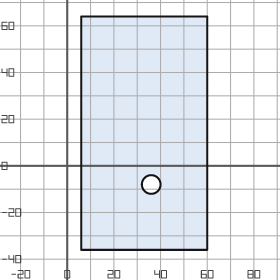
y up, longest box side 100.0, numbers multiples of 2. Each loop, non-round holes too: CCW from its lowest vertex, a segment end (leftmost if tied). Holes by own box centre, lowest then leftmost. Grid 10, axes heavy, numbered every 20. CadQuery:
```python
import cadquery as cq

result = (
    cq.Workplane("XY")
    .moveTo(6.0, -36.0)
    .lineTo(60.0, -36.0)
    .lineTo(60.0, 64.0)
    .lineTo(6.0, 64.0)
    .close()
    .moveTo(36.0, -8.0)
    .circle(4.0)
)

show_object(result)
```